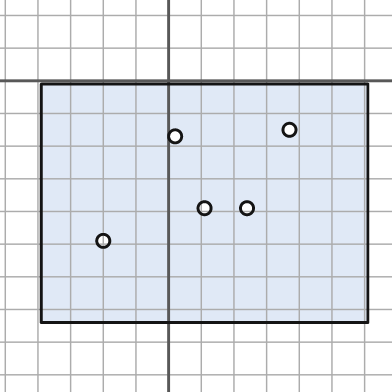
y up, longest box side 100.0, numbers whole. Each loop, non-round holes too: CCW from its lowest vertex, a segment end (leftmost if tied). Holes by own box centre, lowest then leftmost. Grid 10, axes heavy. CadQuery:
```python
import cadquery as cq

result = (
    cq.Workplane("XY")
    .moveTo(-39.0, -74.0)
    .lineTo(61.0, -74.0)
    .lineTo(61.0, -1.0)
    .lineTo(-39.0, -1.0)
    .close()
    .moveTo(-20.0, -49.0)
    .circle(2.0)
    .moveTo(11.0, -39.0)
    .circle(2.0)
    .moveTo(24.0, -39.0)
    .circle(2.0)
    .moveTo(2.0, -17.0)
    .circle(2.0)
    .moveTo(37.0, -15.0)
    .circle(2.0)
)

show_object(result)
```